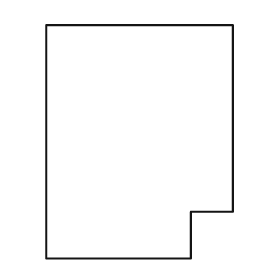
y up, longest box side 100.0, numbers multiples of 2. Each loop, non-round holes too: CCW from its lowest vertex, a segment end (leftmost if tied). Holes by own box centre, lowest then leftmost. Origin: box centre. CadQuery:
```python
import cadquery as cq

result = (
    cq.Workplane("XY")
    .moveTo(-40.0, -50.0)
    .lineTo(22.0, -50.0)
    .lineTo(22.0, -30.0)
    .lineTo(40.0, -30.0)
    .lineTo(40.0, 50.0)
    .lineTo(-40.0, 50.0)
    .close()
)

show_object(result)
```